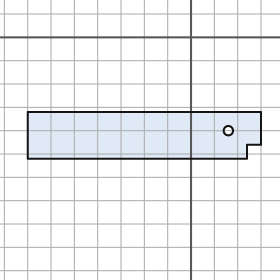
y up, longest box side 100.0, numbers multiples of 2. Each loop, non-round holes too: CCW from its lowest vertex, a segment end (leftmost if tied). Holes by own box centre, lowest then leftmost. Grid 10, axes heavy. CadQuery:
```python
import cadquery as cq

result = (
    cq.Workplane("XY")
    .moveTo(-70.0, -52.0)
    .lineTo(24.0, -52.0)
    .lineTo(24.0, -46.0)
    .lineTo(30.0, -46.0)
    .lineTo(30.0, -32.0)
    .lineTo(-70.0, -32.0)
    .close()
    .moveTo(16.0, -40.0)
    .circle(2.0)
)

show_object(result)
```